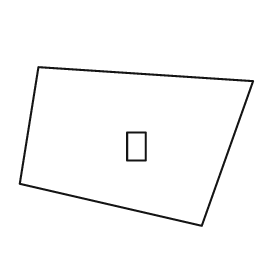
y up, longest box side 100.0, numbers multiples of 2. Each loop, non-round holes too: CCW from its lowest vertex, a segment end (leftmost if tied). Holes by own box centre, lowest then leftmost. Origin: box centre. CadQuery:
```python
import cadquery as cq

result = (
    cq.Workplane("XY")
    .moveTo(28.0, -34.0)
    .lineTo(50.0, 28.0)
    .lineTo(-42.0, 34.0)
    .lineTo(-50.0, -16.0)
    .close()
    .moveTo(-4.0, -6.0)
    .lineTo(4.0, -6.0)
    .lineTo(4.0, 6.0)
    .lineTo(-4.0, 6.0)
    .close()
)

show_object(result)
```